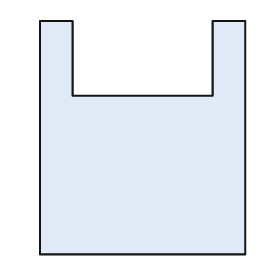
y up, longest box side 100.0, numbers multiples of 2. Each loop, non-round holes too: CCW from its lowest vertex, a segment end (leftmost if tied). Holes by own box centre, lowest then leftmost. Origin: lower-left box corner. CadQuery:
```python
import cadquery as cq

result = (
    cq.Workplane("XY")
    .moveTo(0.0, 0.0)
    .lineTo(88.0, 0.0)
    .lineTo(88.0, 100.0)
    .lineTo(74.0, 100.0)
    .lineTo(74.0, 68.0)
    .lineTo(14.0, 68.0)
    .lineTo(14.0, 100.0)
    .lineTo(0.0, 100.0)
    .close()
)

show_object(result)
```